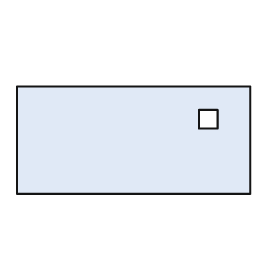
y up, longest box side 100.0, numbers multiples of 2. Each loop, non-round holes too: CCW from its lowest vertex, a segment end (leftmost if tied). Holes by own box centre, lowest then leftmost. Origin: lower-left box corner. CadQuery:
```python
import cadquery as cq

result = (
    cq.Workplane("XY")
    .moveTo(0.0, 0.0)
    .lineTo(100.0, 0.0)
    .lineTo(100.0, 46.0)
    .lineTo(0.0, 46.0)
    .close()
    .moveTo(78.0, 28.0)
    .lineTo(86.0, 28.0)
    .lineTo(86.0, 36.0)
    .lineTo(78.0, 36.0)
    .close()
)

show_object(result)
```